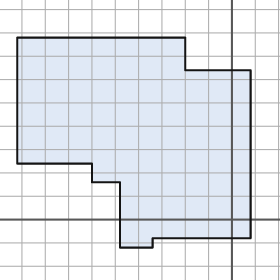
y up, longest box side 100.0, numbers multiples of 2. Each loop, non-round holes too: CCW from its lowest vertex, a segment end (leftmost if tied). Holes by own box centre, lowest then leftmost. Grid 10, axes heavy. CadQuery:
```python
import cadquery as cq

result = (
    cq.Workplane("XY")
    .moveTo(-48.0, -12.0)
    .lineTo(-34.0, -12.0)
    .lineTo(-34.0, -8.0)
    .lineTo(8.0, -8.0)
    .lineTo(8.0, 64.0)
    .lineTo(-20.0, 64.0)
    .lineTo(-20.0, 78.0)
    .lineTo(-92.0, 78.0)
    .lineTo(-92.0, 24.0)
    .lineTo(-60.0, 24.0)
    .lineTo(-60.0, 16.0)
    .lineTo(-48.0, 16.0)
    .close()
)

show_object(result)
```